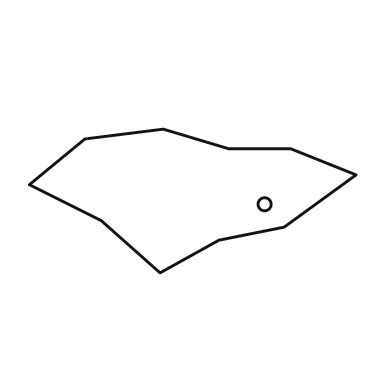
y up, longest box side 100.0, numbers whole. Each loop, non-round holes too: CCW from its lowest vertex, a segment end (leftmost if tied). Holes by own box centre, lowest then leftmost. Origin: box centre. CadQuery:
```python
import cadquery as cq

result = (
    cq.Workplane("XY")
    .moveTo(-10.0, -22.0)
    .lineTo(8.0, -12.0)
    .lineTo(28.0, -8.0)
    .lineTo(50.0, 8.0)
    .lineTo(30.0, 16.0)
    .lineTo(11.0, 16.0)
    .lineTo(-9.0, 22.0)
    .lineTo(-33.0, 19.0)
    .lineTo(-50.0, 5.0)
    .lineTo(-28.0, -6.0)
    .close()
    .moveTo(22.0, -1.0)
    .circle(2.0)
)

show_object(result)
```